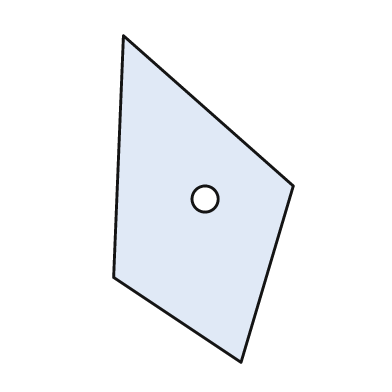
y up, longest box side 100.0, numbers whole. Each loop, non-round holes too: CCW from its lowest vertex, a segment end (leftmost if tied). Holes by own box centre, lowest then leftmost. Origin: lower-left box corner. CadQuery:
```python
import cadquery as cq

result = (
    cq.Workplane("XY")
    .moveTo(39.0, 0.0)
    .lineTo(55.0, 54.0)
    .lineTo(3.0, 100.0)
    .lineTo(0.0, 26.0)
    .close()
    .moveTo(28.0, 50.0)
    .circle(4.0)
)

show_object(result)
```